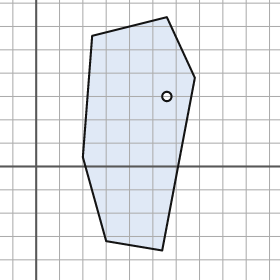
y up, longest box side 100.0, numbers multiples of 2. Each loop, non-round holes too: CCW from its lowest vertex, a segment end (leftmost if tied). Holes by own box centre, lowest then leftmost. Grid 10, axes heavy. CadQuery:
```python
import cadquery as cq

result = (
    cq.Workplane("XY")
    .moveTo(54.0, -36.0)
    .lineTo(68.0, 38.0)
    .lineTo(56.0, 64.0)
    .lineTo(24.0, 56.0)
    .lineTo(20.0, 4.0)
    .lineTo(30.0, -32.0)
    .close()
    .moveTo(56.0, 30.0)
    .circle(2.0)
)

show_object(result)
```